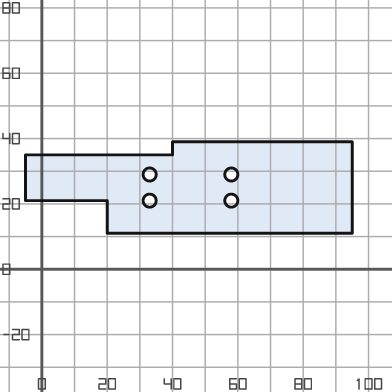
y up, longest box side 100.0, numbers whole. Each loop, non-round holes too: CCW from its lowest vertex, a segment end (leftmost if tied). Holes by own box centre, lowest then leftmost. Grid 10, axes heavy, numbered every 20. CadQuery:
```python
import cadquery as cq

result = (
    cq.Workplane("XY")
    .moveTo(20.0, 11.0)
    .lineTo(95.0, 11.0)
    .lineTo(95.0, 39.0)
    .lineTo(40.0, 39.0)
    .lineTo(40.0, 35.0)
    .lineTo(-5.0, 35.0)
    .lineTo(-5.0, 21.0)
    .lineTo(20.0, 21.0)
    .close()
    .moveTo(33.0, 21.0)
    .circle(2.0)
    .moveTo(58.0, 21.0)
    .circle(2.0)
    .moveTo(33.0, 29.0)
    .circle(2.0)
    .moveTo(58.0, 29.0)
    .circle(2.0)
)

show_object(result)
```